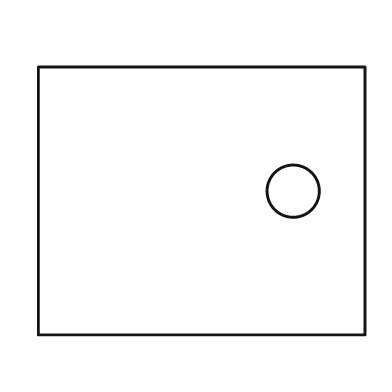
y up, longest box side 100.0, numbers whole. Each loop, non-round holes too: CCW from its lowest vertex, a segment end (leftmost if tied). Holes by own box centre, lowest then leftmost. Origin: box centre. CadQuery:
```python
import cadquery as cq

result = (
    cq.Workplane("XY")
    .moveTo(-50.0, -41.0)
    .lineTo(50.0, -41.0)
    .lineTo(50.0, 41.0)
    .lineTo(-50.0, 41.0)
    .close()
    .moveTo(28.0, 3.0)
    .circle(8.0)
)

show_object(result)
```